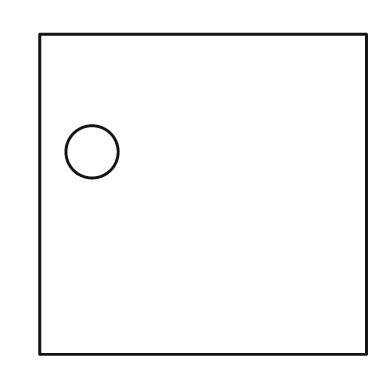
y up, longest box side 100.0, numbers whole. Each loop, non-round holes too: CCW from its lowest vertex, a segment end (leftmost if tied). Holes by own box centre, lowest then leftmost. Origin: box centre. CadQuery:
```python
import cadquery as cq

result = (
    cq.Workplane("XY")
    .moveTo(-50.0, -49.0)
    .lineTo(50.0, -49.0)
    .lineTo(50.0, 49.0)
    .lineTo(-50.0, 49.0)
    .close()
    .moveTo(-34.0, 13.0)
    .circle(8.0)
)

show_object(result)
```